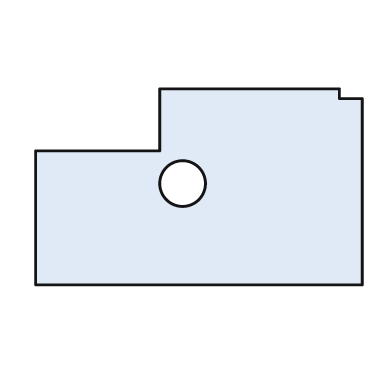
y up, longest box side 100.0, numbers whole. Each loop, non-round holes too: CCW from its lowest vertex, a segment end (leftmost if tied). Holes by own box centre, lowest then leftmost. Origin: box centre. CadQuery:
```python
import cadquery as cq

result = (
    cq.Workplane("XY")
    .moveTo(-50.0, -30.0)
    .lineTo(50.0, -30.0)
    .lineTo(50.0, 27.0)
    .lineTo(43.0, 27.0)
    .lineTo(43.0, 30.0)
    .lineTo(-12.0, 30.0)
    .lineTo(-12.0, 11.0)
    .lineTo(-50.0, 11.0)
    .close()
    .moveTo(-5.0, 1.0)
    .circle(7.0)
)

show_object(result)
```